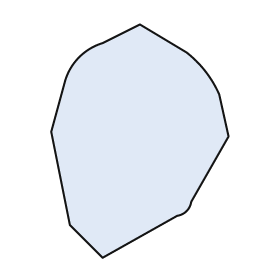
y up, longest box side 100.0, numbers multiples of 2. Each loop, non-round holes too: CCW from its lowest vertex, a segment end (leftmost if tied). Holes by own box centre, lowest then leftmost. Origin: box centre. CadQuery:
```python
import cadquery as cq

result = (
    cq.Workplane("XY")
    .moveTo(-16.0, -50.0)
    .lineTo(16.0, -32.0)
    .threePointArc((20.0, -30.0), (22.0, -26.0))
    .lineTo(38.0, 2.0)
    .lineTo(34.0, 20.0)
    .threePointArc((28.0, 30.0), (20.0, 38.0))
    .lineTo(0.0, 50.0)
    .lineTo(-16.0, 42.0)
    .threePointArc((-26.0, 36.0), (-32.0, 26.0))
    .lineTo(-38.0, 4.0)
    .lineTo(-30.0, -36.0)
    .close()
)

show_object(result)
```